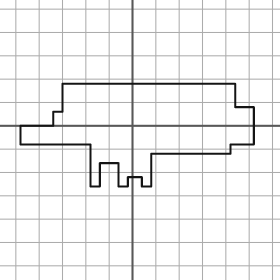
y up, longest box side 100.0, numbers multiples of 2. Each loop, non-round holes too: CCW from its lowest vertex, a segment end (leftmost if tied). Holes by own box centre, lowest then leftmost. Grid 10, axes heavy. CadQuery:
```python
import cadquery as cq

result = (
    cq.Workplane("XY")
    .moveTo(-18.0, -26.0)
    .lineTo(-14.0, -26.0)
    .lineTo(-14.0, -16.0)
    .lineTo(-6.0, -16.0)
    .lineTo(-6.0, -26.0)
    .lineTo(-2.0, -26.0)
    .lineTo(-2.0, -22.0)
    .lineTo(4.0, -22.0)
    .lineTo(4.0, -26.0)
    .lineTo(8.0, -26.0)
    .lineTo(8.0, -12.0)
    .lineTo(42.0, -12.0)
    .lineTo(42.0, -8.0)
    .lineTo(52.0, -8.0)
    .lineTo(52.0, 8.0)
    .lineTo(44.0, 8.0)
    .lineTo(44.0, 18.0)
    .lineTo(-30.0, 18.0)
    .lineTo(-30.0, 6.0)
    .lineTo(-34.0, 6.0)
    .lineTo(-34.0, 0.0)
    .lineTo(-48.0, 0.0)
    .lineTo(-48.0, -8.0)
    .lineTo(-18.0, -8.0)
    .close()
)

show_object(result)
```